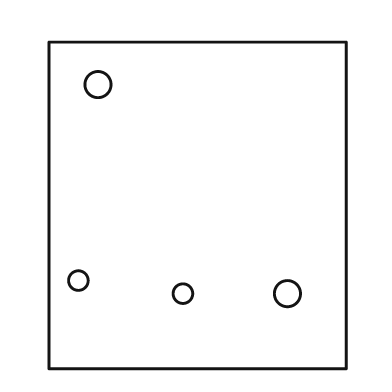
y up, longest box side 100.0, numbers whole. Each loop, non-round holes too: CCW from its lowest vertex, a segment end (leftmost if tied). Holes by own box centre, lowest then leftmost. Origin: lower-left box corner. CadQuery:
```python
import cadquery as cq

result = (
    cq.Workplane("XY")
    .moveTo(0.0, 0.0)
    .lineTo(91.0, 0.0)
    .lineTo(91.0, 100.0)
    .lineTo(0.0, 100.0)
    .close()
    .moveTo(41.0, 23.0)
    .circle(3.0)
    .moveTo(73.0, 23.0)
    .circle(4.0)
    .moveTo(9.0, 27.0)
    .circle(3.0)
    .moveTo(15.0, 87.0)
    .circle(4.0)
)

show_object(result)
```